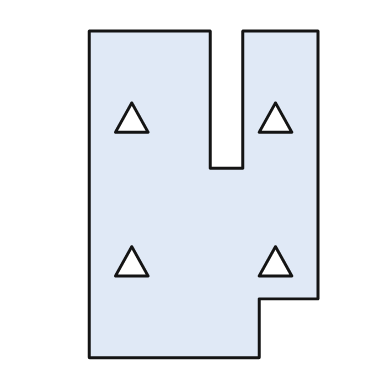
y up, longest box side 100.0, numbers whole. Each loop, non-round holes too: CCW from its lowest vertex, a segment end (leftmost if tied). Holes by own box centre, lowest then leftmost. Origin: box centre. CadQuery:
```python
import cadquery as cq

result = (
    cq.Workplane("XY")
    .moveTo(-35.0, -50.0)
    .lineTo(17.0, -50.0)
    .lineTo(17.0, -32.0)
    .lineTo(35.0, -32.0)
    .lineTo(35.0, 50.0)
    .lineTo(12.0, 50.0)
    .lineTo(12.0, 8.0)
    .lineTo(2.0, 8.0)
    .lineTo(2.0, 50.0)
    .lineTo(-35.0, 50.0)
    .close()
    .moveTo(-27.0, -25.0)
    .lineTo(-17.0, -25.0)
    .lineTo(-22.0, -16.0)
    .close()
    .moveTo(17.0, -25.0)
    .lineTo(27.0, -25.0)
    .lineTo(22.0, -16.0)
    .close()
    .moveTo(-27.0, 19.0)
    .lineTo(-17.0, 19.0)
    .lineTo(-22.0, 28.0)
    .close()
    .moveTo(17.0, 19.0)
    .lineTo(27.0, 19.0)
    .lineTo(22.0, 28.0)
    .close()
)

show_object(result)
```